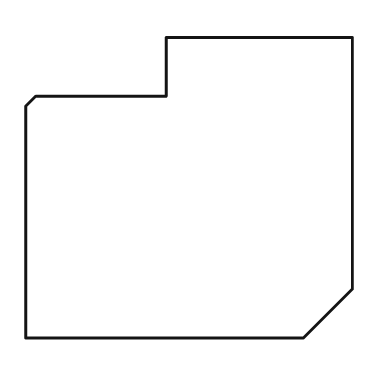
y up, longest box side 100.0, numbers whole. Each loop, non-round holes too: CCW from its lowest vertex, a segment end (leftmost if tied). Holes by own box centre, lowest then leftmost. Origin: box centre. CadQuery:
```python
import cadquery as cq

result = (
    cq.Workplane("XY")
    .moveTo(-50.0, -46.0)
    .lineTo(35.0, -46.0)
    .lineTo(50.0, -31.0)
    .lineTo(50.0, 46.0)
    .lineTo(-7.0, 46.0)
    .lineTo(-7.0, 28.0)
    .lineTo(-47.0, 28.0)
    .lineTo(-50.0, 25.0)
    .close()
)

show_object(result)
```